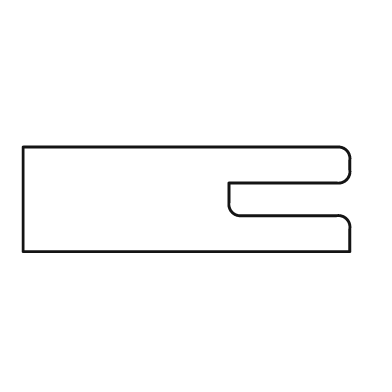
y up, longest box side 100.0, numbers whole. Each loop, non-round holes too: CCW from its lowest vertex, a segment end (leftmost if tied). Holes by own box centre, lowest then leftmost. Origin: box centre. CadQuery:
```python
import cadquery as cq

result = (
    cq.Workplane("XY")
    .moveTo(-50.0, -16.0)
    .lineTo(50.0, -16.0)
    .lineTo(50.0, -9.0)
    .threePointArc((49.0, -6.0), (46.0, -5.0))
    .lineTo(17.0, -5.0)
    .threePointArc((14.0, -4.0), (13.0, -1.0))
    .lineTo(13.0, 5.0)
    .lineTo(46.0, 5.0)
    .threePointArc((49.0, 6.0), (50.0, 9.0))
    .lineTo(50.0, 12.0)
    .threePointArc((49.0, 15.0), (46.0, 16.0))
    .lineTo(-50.0, 16.0)
    .close()
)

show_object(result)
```